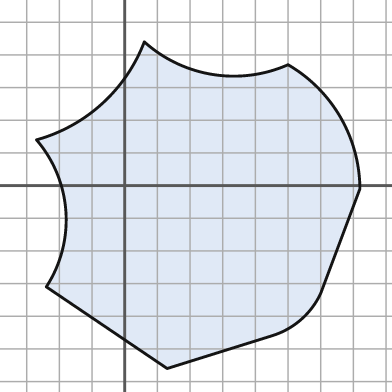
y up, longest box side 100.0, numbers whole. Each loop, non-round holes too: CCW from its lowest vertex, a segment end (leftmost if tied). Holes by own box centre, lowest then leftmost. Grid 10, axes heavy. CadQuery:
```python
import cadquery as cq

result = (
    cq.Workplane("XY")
    .moveTo(13.0, -56.0)
    .lineTo(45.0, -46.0)
    .threePointArc((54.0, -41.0), (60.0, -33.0))
    .lineTo(72.0, -1.0)
    .threePointArc((66.0, 21.0), (50.0, 37.0))
    .threePointArc((27.0, 34.0), (6.0, 44.0))
    .threePointArc((-7.0, 25.0), (-27.0, 14.0))
    .threePointArc((-18.0, -8.0), (-24.0, -31.0))
    .close()
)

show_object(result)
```